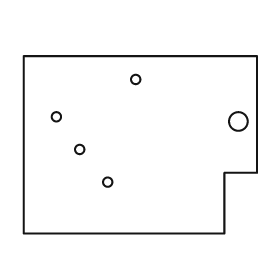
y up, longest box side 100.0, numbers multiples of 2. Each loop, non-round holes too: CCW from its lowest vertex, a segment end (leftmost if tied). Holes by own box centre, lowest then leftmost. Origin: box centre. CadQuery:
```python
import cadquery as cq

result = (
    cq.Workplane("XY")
    .moveTo(-50.0, -38.0)
    .lineTo(36.0, -38.0)
    .lineTo(36.0, -12.0)
    .lineTo(50.0, -12.0)
    .lineTo(50.0, 38.0)
    .lineTo(-50.0, 38.0)
    .close()
    .moveTo(-14.0, -16.0)
    .circle(2.0)
    .moveTo(-26.0, -2.0)
    .circle(2.0)
    .moveTo(42.0, 10.0)
    .circle(4.0)
    .moveTo(-36.0, 12.0)
    .circle(2.0)
    .moveTo(-2.0, 28.0)
    .circle(2.0)
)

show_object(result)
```